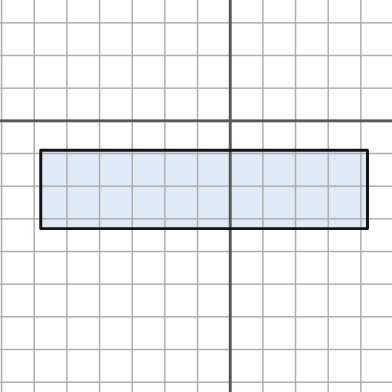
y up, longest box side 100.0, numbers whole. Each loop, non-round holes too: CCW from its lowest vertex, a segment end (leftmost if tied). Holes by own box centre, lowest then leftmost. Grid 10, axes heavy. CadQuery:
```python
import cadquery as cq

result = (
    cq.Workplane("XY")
    .moveTo(-58.0, -33.0)
    .lineTo(42.0, -33.0)
    .lineTo(42.0, -9.0)
    .lineTo(-58.0, -9.0)
    .close()
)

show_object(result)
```